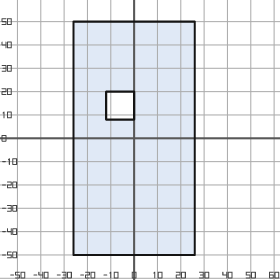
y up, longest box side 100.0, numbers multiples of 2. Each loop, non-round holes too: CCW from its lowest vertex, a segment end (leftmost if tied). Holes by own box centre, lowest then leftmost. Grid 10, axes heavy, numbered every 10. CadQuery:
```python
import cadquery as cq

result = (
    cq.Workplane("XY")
    .moveTo(-26.0, -50.0)
    .lineTo(26.0, -50.0)
    .lineTo(26.0, 50.0)
    .lineTo(-26.0, 50.0)
    .close()
    .moveTo(-12.0, 8.0)
    .lineTo(0.0, 8.0)
    .lineTo(0.0, 20.0)
    .lineTo(-12.0, 20.0)
    .close()
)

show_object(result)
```